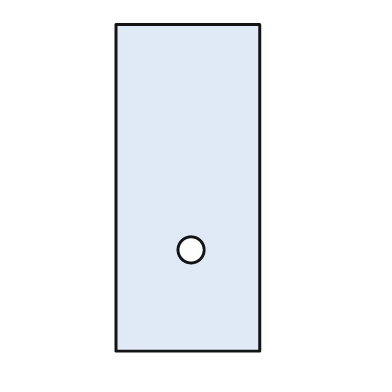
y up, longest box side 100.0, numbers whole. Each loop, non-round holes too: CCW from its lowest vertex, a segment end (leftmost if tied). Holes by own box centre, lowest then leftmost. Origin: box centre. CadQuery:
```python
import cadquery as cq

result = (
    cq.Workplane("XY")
    .moveTo(-22.0, -50.0)
    .lineTo(22.0, -50.0)
    .lineTo(22.0, 50.0)
    .lineTo(-22.0, 50.0)
    .close()
    .moveTo(1.0, -19.0)
    .circle(4.0)
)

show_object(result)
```